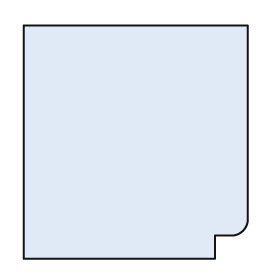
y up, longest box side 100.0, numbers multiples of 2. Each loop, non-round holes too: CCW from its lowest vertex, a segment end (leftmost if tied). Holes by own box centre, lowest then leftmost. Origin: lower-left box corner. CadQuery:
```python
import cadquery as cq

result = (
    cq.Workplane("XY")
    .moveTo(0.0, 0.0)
    .lineTo(82.0, 0.0)
    .lineTo(82.0, 10.0)
    .lineTo(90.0, 10.0)
    .threePointArc((94.0, 12.0), (96.0, 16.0))
    .lineTo(96.0, 100.0)
    .lineTo(0.0, 100.0)
    .close()
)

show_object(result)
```